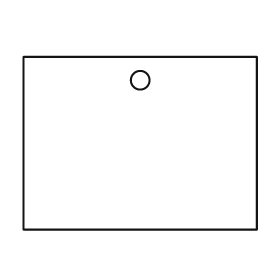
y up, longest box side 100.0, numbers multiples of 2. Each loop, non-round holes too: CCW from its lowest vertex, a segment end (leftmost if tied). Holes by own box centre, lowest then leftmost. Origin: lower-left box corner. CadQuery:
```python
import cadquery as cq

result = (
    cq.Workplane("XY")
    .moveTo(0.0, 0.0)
    .lineTo(100.0, 0.0)
    .lineTo(100.0, 74.0)
    .lineTo(0.0, 74.0)
    .close()
    .moveTo(50.0, 64.0)
    .circle(4.0)
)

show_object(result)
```